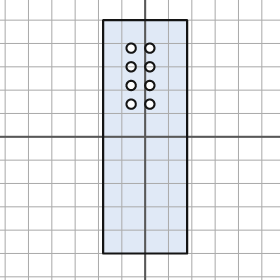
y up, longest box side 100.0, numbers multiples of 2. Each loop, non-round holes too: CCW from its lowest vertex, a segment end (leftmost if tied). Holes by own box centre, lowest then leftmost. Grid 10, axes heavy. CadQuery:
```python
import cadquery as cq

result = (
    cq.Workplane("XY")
    .moveTo(-18.0, -50.0)
    .lineTo(18.0, -50.0)
    .lineTo(18.0, 50.0)
    .lineTo(-18.0, 50.0)
    .close()
    .moveTo(-6.0, 14.0)
    .circle(2.0)
    .moveTo(2.0, 14.0)
    .circle(2.0)
    .moveTo(-6.0, 22.0)
    .circle(2.0)
    .moveTo(2.0, 22.0)
    .circle(2.0)
    .moveTo(-6.0, 30.0)
    .circle(2.0)
    .moveTo(2.0, 30.0)
    .circle(2.0)
    .moveTo(-6.0, 38.0)
    .circle(2.0)
    .moveTo(2.0, 38.0)
    .circle(2.0)
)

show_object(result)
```